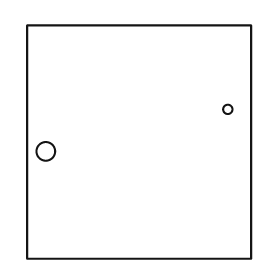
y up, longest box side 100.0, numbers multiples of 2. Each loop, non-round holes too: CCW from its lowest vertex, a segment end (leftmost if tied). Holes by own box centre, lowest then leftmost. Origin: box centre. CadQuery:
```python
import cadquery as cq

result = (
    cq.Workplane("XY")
    .moveTo(-48.0, -50.0)
    .lineTo(48.0, -50.0)
    .lineTo(48.0, 50.0)
    .lineTo(-48.0, 50.0)
    .close()
    .moveTo(-40.0, -4.0)
    .circle(4.0)
    .moveTo(38.0, 14.0)
    .circle(2.0)
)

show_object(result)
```